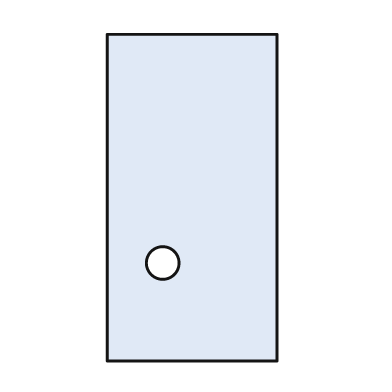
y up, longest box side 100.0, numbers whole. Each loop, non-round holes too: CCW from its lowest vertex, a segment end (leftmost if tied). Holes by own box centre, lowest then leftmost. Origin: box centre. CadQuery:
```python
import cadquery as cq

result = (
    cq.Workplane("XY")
    .moveTo(-26.0, -50.0)
    .lineTo(26.0, -50.0)
    .lineTo(26.0, 50.0)
    .lineTo(-26.0, 50.0)
    .close()
    .moveTo(-9.0, -20.0)
    .circle(5.0)
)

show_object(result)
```